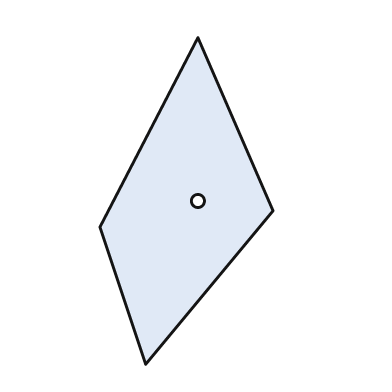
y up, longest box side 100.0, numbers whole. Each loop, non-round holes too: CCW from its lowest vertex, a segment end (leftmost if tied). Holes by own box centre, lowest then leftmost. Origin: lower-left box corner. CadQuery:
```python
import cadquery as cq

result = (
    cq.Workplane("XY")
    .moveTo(14.0, 0.0)
    .lineTo(53.0, 47.0)
    .lineTo(30.0, 100.0)
    .lineTo(0.0, 42.0)
    .close()
    .moveTo(30.0, 50.0)
    .circle(2.0)
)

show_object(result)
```